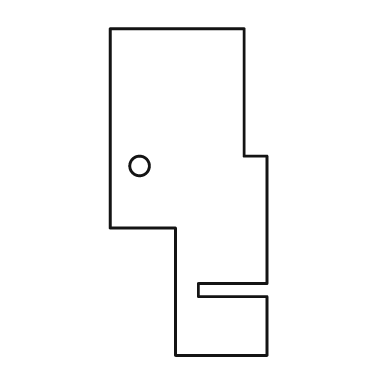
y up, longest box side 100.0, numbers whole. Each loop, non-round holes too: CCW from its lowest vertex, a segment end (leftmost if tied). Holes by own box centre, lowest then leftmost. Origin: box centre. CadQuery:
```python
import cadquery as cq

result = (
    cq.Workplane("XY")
    .moveTo(-4.0, -50.0)
    .lineTo(24.0, -50.0)
    .lineTo(24.0, -32.0)
    .lineTo(3.0, -32.0)
    .lineTo(3.0, -28.0)
    .lineTo(24.0, -28.0)
    .lineTo(24.0, 11.0)
    .lineTo(17.0, 11.0)
    .lineTo(17.0, 50.0)
    .lineTo(-24.0, 50.0)
    .lineTo(-24.0, -11.0)
    .lineTo(-4.0, -11.0)
    .close()
    .moveTo(-15.0, 8.0)
    .circle(3.0)
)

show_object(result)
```